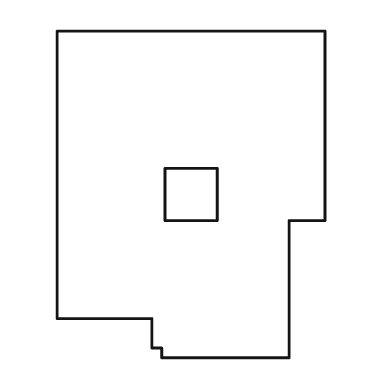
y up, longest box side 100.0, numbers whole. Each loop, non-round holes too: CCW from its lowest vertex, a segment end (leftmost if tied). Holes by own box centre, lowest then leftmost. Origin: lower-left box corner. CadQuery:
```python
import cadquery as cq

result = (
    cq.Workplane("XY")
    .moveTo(32.0, 0.0)
    .lineTo(71.0, 0.0)
    .lineTo(71.0, 42.0)
    .lineTo(82.0, 42.0)
    .lineTo(82.0, 100.0)
    .lineTo(0.0, 100.0)
    .lineTo(0.0, 12.0)
    .lineTo(29.0, 12.0)
    .lineTo(29.0, 3.0)
    .lineTo(32.0, 3.0)
    .close()
    .moveTo(33.0, 42.0)
    .lineTo(49.0, 42.0)
    .lineTo(49.0, 58.0)
    .lineTo(33.0, 58.0)
    .close()
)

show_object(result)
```